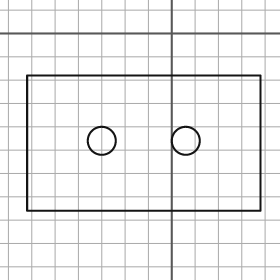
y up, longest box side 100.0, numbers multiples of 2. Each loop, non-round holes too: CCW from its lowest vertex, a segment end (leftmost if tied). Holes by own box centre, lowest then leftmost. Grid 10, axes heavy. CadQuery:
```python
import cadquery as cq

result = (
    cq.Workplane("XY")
    .moveTo(-62.0, -76.0)
    .lineTo(38.0, -76.0)
    .lineTo(38.0, -18.0)
    .lineTo(-62.0, -18.0)
    .close()
    .moveTo(-30.0, -46.0)
    .circle(6.0)
    .moveTo(6.0, -46.0)
    .circle(6.0)
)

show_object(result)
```